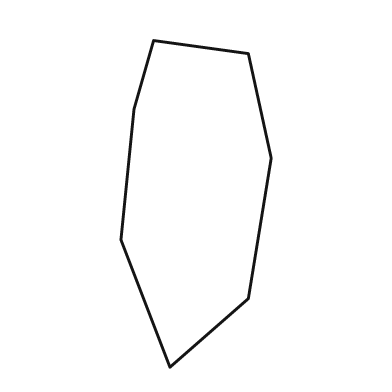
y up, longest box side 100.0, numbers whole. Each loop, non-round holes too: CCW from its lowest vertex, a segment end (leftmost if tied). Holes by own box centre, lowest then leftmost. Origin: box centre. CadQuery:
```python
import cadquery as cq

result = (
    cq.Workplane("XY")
    .moveTo(-8.0, -50.0)
    .lineTo(16.0, -29.0)
    .lineTo(23.0, 14.0)
    .lineTo(16.0, 46.0)
    .lineTo(-13.0, 50.0)
    .lineTo(-19.0, 29.0)
    .lineTo(-23.0, -11.0)
    .close()
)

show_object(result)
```